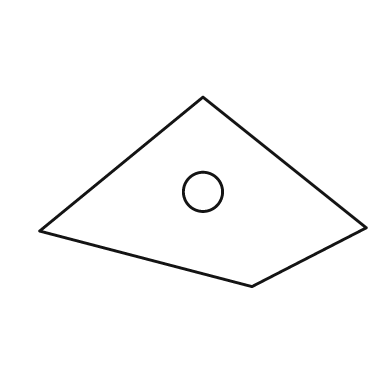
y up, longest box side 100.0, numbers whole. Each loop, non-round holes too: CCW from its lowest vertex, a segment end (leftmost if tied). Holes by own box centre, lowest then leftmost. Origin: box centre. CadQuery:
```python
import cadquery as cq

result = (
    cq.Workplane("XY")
    .moveTo(15.0, -29.0)
    .lineTo(50.0, -11.0)
    .lineTo(0.0, 29.0)
    .lineTo(-50.0, -12.0)
    .close()
    .moveTo(0.0, 0.0)
    .circle(6.0)
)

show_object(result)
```